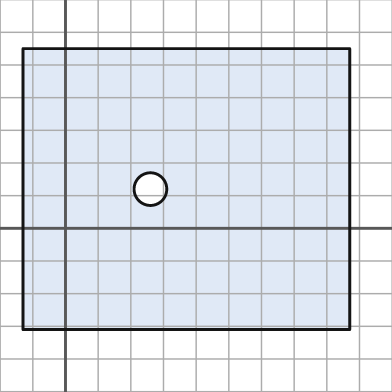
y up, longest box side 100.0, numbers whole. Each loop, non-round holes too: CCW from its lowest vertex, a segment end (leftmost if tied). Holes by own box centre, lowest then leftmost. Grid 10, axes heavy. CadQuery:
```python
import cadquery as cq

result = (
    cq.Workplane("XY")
    .moveTo(-13.0, -31.0)
    .lineTo(87.0, -31.0)
    .lineTo(87.0, 55.0)
    .lineTo(-13.0, 55.0)
    .close()
    .moveTo(26.0, 12.0)
    .circle(5.0)
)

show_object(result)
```